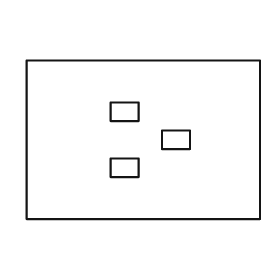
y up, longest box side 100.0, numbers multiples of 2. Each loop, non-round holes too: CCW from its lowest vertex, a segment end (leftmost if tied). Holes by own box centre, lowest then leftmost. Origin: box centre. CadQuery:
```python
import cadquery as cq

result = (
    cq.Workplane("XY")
    .moveTo(-50.0, -34.0)
    .lineTo(50.0, -34.0)
    .lineTo(50.0, 34.0)
    .lineTo(-50.0, 34.0)
    .close()
    .moveTo(-14.0, -16.0)
    .lineTo(-2.0, -16.0)
    .lineTo(-2.0, -8.0)
    .lineTo(-14.0, -8.0)
    .close()
    .moveTo(8.0, -4.0)
    .lineTo(20.0, -4.0)
    .lineTo(20.0, 4.0)
    .lineTo(8.0, 4.0)
    .close()
    .moveTo(-14.0, 8.0)
    .lineTo(-2.0, 8.0)
    .lineTo(-2.0, 16.0)
    .lineTo(-14.0, 16.0)
    .close()
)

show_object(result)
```